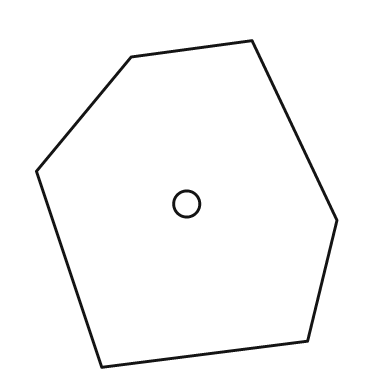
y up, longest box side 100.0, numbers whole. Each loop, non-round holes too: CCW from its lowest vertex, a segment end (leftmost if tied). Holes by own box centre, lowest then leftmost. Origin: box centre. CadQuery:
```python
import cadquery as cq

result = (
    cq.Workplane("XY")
    .moveTo(-26.0, -50.0)
    .lineTo(37.0, -42.0)
    .lineTo(46.0, -5.0)
    .lineTo(20.0, 50.0)
    .lineTo(-17.0, 45.0)
    .lineTo(-46.0, 10.0)
    .close()
    .moveTo(0.0, 0.0)
    .circle(4.0)
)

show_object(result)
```